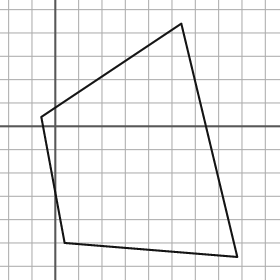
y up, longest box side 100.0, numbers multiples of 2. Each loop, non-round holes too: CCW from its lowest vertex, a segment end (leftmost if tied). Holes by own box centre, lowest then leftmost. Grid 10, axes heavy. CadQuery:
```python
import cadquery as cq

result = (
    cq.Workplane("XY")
    .moveTo(78.0, -56.0)
    .lineTo(54.0, 44.0)
    .lineTo(-6.0, 4.0)
    .lineTo(4.0, -50.0)
    .close()
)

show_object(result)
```